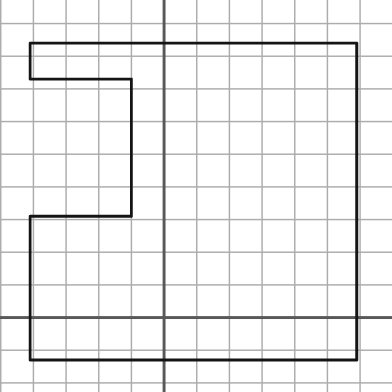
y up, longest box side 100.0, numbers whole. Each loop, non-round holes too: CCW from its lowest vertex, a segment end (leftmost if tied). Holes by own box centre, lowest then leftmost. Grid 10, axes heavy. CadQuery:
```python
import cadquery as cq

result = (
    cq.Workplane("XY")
    .moveTo(-41.0, -13.0)
    .lineTo(59.0, -13.0)
    .lineTo(59.0, 84.0)
    .lineTo(-41.0, 84.0)
    .lineTo(-41.0, 73.0)
    .lineTo(-10.0, 73.0)
    .lineTo(-10.0, 31.0)
    .lineTo(-41.0, 31.0)
    .close()
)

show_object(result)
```